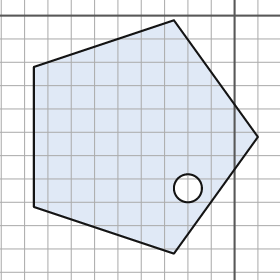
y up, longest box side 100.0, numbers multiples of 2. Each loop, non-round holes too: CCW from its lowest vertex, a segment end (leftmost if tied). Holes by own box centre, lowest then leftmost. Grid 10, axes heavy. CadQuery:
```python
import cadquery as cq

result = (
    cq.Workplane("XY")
    .moveTo(-26.0, -102.0)
    .lineTo(10.0, -52.0)
    .lineTo(-26.0, -2.0)
    .lineTo(-86.0, -22.0)
    .lineTo(-86.0, -82.0)
    .close()
    .moveTo(-20.0, -74.0)
    .circle(6.0)
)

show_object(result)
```